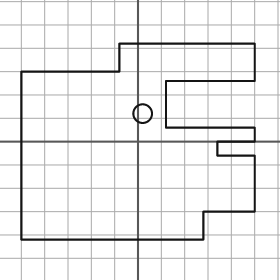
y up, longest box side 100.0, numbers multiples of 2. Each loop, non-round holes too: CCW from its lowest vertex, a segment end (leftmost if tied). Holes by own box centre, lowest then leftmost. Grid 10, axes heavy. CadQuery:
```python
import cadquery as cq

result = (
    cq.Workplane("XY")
    .moveTo(-50.0, -42.0)
    .lineTo(28.0, -42.0)
    .lineTo(28.0, -30.0)
    .lineTo(50.0, -30.0)
    .lineTo(50.0, -6.0)
    .lineTo(34.0, -6.0)
    .lineTo(34.0, 0.0)
    .lineTo(50.0, 0.0)
    .lineTo(50.0, 6.0)
    .lineTo(12.0, 6.0)
    .lineTo(12.0, 26.0)
    .lineTo(50.0, 26.0)
    .lineTo(50.0, 42.0)
    .lineTo(-8.0, 42.0)
    .lineTo(-8.0, 30.0)
    .lineTo(-50.0, 30.0)
    .close()
    .moveTo(2.0, 12.0)
    .circle(4.0)
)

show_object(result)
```